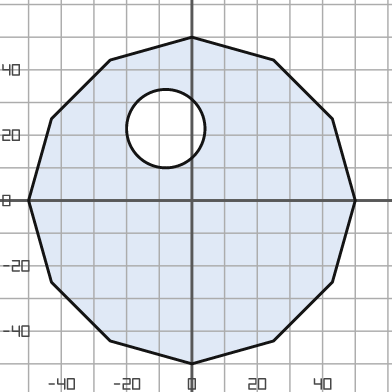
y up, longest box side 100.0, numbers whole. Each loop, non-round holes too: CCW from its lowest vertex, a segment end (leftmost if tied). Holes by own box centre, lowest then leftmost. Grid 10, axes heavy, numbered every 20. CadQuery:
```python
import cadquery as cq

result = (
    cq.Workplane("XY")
    .moveTo(0.0, -50.0)
    .lineTo(25.0, -43.0)
    .lineTo(43.0, -25.0)
    .lineTo(50.0, 0.0)
    .lineTo(43.0, 25.0)
    .lineTo(25.0, 43.0)
    .lineTo(0.0, 50.0)
    .lineTo(-25.0, 43.0)
    .lineTo(-43.0, 25.0)
    .lineTo(-50.0, 0.0)
    .lineTo(-43.0, -25.0)
    .lineTo(-25.0, -43.0)
    .close()
    .moveTo(-8.0, 22.0)
    .circle(12.0)
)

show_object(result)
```